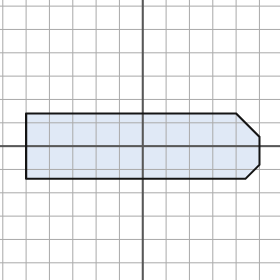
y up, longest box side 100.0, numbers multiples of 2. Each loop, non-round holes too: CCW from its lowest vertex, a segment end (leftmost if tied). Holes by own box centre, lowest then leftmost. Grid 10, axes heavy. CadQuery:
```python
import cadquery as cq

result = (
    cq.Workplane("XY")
    .moveTo(-50.0, -14.0)
    .lineTo(44.0, -14.0)
    .lineTo(50.0, -8.0)
    .lineTo(50.0, 4.0)
    .lineTo(40.0, 14.0)
    .lineTo(-50.0, 14.0)
    .close()
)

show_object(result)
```